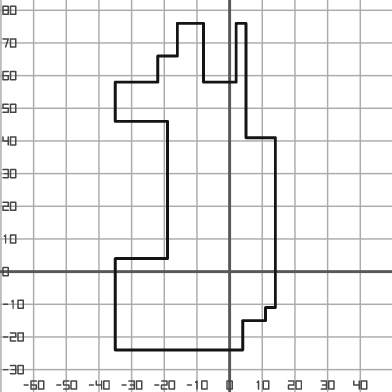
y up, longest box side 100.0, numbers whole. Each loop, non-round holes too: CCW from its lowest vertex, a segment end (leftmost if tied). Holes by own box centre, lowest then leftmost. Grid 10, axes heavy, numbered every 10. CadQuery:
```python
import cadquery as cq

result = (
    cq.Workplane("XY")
    .moveTo(-35.0, -24.0)
    .lineTo(4.0, -24.0)
    .lineTo(4.0, -15.0)
    .lineTo(11.0, -15.0)
    .lineTo(11.0, -11.0)
    .lineTo(14.0, -11.0)
    .lineTo(14.0, 41.0)
    .lineTo(5.0, 41.0)
    .lineTo(5.0, 76.0)
    .lineTo(2.0, 76.0)
    .lineTo(2.0, 58.0)
    .lineTo(-8.0, 58.0)
    .lineTo(-8.0, 76.0)
    .lineTo(-16.0, 76.0)
    .lineTo(-16.0, 66.0)
    .lineTo(-22.0, 66.0)
    .lineTo(-22.0, 58.0)
    .lineTo(-35.0, 58.0)
    .lineTo(-35.0, 46.0)
    .lineTo(-19.0, 46.0)
    .lineTo(-19.0, 4.0)
    .lineTo(-35.0, 4.0)
    .close()
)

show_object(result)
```